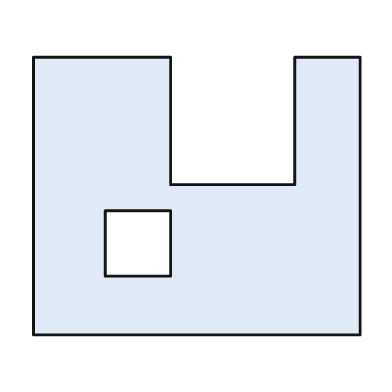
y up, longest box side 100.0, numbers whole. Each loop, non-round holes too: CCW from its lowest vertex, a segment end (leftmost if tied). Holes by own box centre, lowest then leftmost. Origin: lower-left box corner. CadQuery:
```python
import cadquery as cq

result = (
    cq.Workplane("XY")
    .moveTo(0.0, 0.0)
    .lineTo(100.0, 0.0)
    .lineTo(100.0, 85.0)
    .lineTo(80.0, 85.0)
    .lineTo(80.0, 46.0)
    .lineTo(42.0, 46.0)
    .lineTo(42.0, 85.0)
    .lineTo(0.0, 85.0)
    .close()
    .moveTo(22.0, 18.0)
    .lineTo(42.0, 18.0)
    .lineTo(42.0, 38.0)
    .lineTo(22.0, 38.0)
    .close()
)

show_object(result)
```